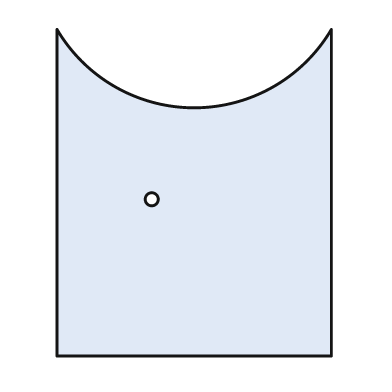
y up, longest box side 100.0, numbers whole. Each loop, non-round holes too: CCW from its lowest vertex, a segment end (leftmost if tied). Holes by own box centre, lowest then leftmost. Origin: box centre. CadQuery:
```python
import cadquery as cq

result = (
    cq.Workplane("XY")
    .moveTo(-42.0, -50.0)
    .lineTo(42.0, -50.0)
    .lineTo(42.0, 50.0)
    .threePointArc((0.0, 26.0), (-42.0, 50.0))
    .close()
    .moveTo(-13.0, -2.0)
    .circle(2.0)
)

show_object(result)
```